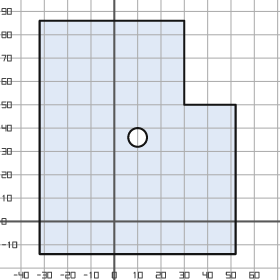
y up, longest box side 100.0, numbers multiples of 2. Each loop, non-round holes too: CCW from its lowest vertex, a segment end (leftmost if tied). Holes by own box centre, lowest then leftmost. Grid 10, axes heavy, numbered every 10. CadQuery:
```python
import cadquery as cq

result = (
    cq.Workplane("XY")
    .moveTo(-32.0, -14.0)
    .lineTo(52.0, -14.0)
    .lineTo(52.0, 50.0)
    .lineTo(30.0, 50.0)
    .lineTo(30.0, 86.0)
    .lineTo(-32.0, 86.0)
    .close()
    .moveTo(10.0, 36.0)
    .circle(4.0)
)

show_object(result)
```